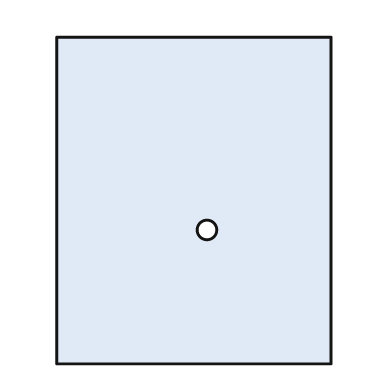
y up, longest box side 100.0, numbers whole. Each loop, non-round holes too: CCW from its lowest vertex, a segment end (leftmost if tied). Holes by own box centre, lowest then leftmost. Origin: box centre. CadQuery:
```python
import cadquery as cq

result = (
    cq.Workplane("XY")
    .moveTo(-42.0, -50.0)
    .lineTo(42.0, -50.0)
    .lineTo(42.0, 50.0)
    .lineTo(-42.0, 50.0)
    .close()
    .moveTo(4.0, -9.0)
    .circle(3.0)
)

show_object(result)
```